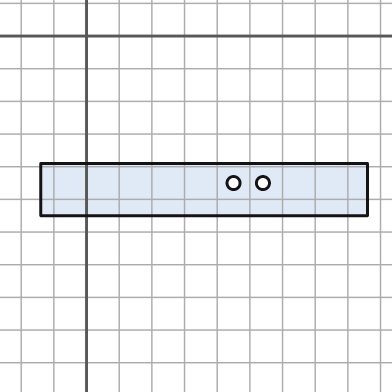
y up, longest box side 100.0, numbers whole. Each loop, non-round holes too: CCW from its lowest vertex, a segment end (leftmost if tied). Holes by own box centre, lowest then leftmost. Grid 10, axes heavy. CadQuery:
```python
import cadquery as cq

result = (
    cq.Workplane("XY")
    .moveTo(-14.0, -55.0)
    .lineTo(86.0, -55.0)
    .lineTo(86.0, -39.0)
    .lineTo(-14.0, -39.0)
    .close()
    .moveTo(45.0, -45.0)
    .circle(2.0)
    .moveTo(54.0, -45.0)
    .circle(2.0)
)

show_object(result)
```